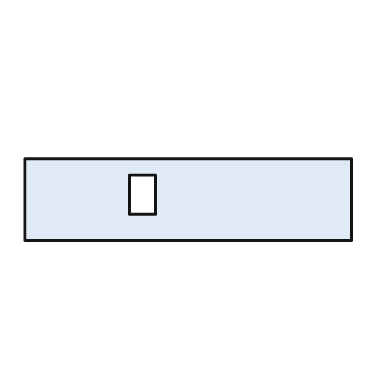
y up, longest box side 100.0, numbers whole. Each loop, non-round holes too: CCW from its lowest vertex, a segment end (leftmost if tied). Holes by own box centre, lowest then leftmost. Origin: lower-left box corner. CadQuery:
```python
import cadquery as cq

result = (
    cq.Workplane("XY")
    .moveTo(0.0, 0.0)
    .lineTo(100.0, 0.0)
    .lineTo(100.0, 25.0)
    .lineTo(0.0, 25.0)
    .close()
    .moveTo(32.0, 8.0)
    .lineTo(40.0, 8.0)
    .lineTo(40.0, 20.0)
    .lineTo(32.0, 20.0)
    .close()
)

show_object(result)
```